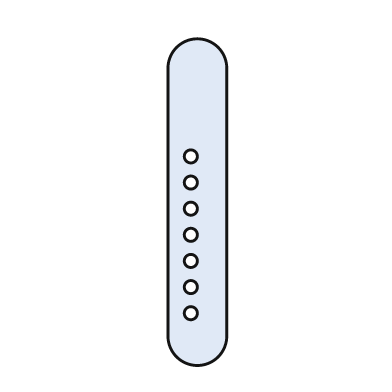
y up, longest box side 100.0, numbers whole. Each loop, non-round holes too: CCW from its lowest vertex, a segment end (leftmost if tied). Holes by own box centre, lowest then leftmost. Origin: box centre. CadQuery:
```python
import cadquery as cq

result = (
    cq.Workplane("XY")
    .moveTo(-9.0, -41.0)
    .threePointArc((0.0, -50.0), (9.0, -41.0))
    .lineTo(9.0, 41.0)
    .threePointArc((0.0, 50.0), (-9.0, 41.0))
    .close()
    .moveTo(-2.0, -34.0)
    .circle(2.0)
    .moveTo(-2.0, -26.0)
    .circle(2.0)
    .moveTo(-2.0, -18.0)
    .circle(2.0)
    .moveTo(-2.0, -10.0)
    .circle(2.0)
    .moveTo(-2.0, -2.0)
    .circle(2.0)
    .moveTo(-2.0, 6.0)
    .circle(2.0)
    .moveTo(-2.0, 14.0)
    .circle(2.0)
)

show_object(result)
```